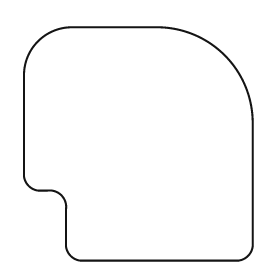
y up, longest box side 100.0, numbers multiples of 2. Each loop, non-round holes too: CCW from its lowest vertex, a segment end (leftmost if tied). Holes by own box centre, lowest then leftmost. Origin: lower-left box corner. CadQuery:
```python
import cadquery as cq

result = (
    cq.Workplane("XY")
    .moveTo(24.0, 0.0)
    .lineTo(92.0, 0.0)
    .threePointArc((96.0, 2.0), (98.0, 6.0))
    .lineTo(98.0, 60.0)
    .threePointArc((86.0, 88.0), (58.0, 100.0))
    .lineTo(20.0, 100.0)
    .threePointArc((6.0, 94.0), (0.0, 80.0))
    .lineTo(0.0, 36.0)
    .threePointArc((2.0, 32.0), (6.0, 30.0))
    .lineTo(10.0, 30.0)
    .threePointArc((16.0, 28.0), (18.0, 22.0))
    .lineTo(18.0, 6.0)
    .threePointArc((20.0, 2.0), (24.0, 0.0))
    .close()
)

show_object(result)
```